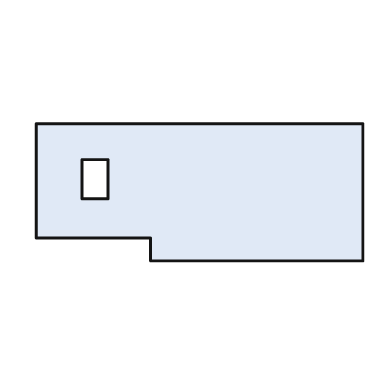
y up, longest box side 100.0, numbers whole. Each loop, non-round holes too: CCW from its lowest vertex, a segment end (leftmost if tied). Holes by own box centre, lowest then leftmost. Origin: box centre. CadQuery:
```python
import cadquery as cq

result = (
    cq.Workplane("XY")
    .moveTo(-15.0, -21.0)
    .lineTo(50.0, -21.0)
    .lineTo(50.0, 21.0)
    .lineTo(-50.0, 21.0)
    .lineTo(-50.0, -14.0)
    .lineTo(-15.0, -14.0)
    .close()
    .moveTo(-36.0, -2.0)
    .lineTo(-28.0, -2.0)
    .lineTo(-28.0, 10.0)
    .lineTo(-36.0, 10.0)
    .close()
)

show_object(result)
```